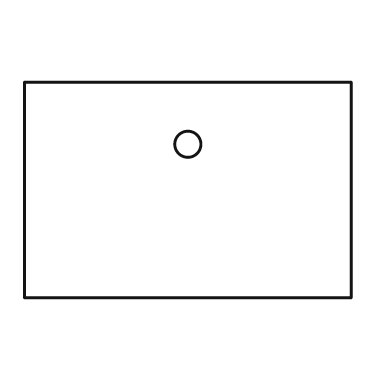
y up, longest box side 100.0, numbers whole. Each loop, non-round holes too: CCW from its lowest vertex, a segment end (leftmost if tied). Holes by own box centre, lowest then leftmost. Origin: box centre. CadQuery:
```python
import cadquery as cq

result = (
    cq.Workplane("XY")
    .moveTo(-50.0, -33.0)
    .lineTo(50.0, -33.0)
    .lineTo(50.0, 33.0)
    .lineTo(-50.0, 33.0)
    .close()
    .moveTo(0.0, 14.0)
    .circle(4.0)
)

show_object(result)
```